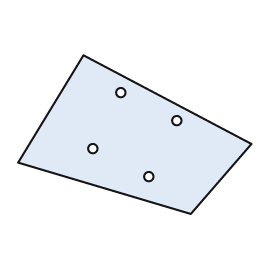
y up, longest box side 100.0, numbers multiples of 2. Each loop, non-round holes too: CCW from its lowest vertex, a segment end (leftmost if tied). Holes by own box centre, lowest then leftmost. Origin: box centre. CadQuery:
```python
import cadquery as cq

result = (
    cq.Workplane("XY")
    .moveTo(24.0, -34.0)
    .lineTo(50.0, -4.0)
    .lineTo(-22.0, 34.0)
    .lineTo(-50.0, -12.0)
    .close()
    .moveTo(6.0, -18.0)
    .circle(2.0)
    .moveTo(-18.0, -6.0)
    .circle(2.0)
    .moveTo(18.0, 6.0)
    .circle(2.0)
    .moveTo(-6.0, 18.0)
    .circle(2.0)
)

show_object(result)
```